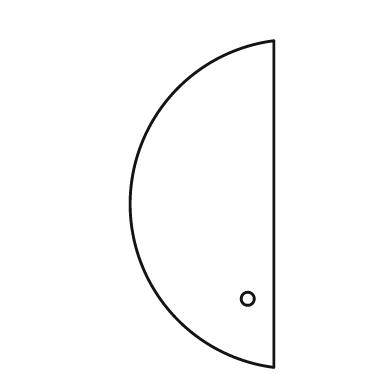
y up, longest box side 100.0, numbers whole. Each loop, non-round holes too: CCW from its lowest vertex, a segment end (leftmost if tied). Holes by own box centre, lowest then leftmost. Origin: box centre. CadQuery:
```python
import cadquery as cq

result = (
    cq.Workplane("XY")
    .moveTo(22.0, -50.0)
    .lineTo(22.0, 50.0)
    .threePointArc((-22.0, 0.0), (22.0, -50.0))
    .close()
    .moveTo(14.0, -29.0)
    .circle(2.0)
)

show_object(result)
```